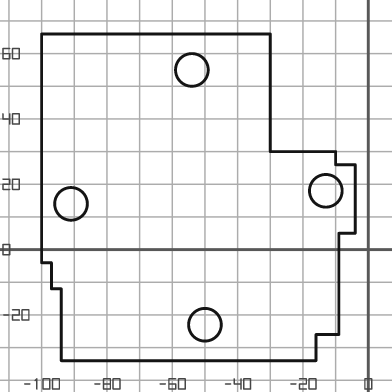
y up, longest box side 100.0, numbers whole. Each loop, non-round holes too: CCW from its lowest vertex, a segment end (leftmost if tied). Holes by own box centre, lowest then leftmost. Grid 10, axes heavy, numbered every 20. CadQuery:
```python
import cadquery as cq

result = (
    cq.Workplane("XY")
    .moveTo(-94.0, -34.0)
    .lineTo(-16.0, -34.0)
    .lineTo(-16.0, -26.0)
    .lineTo(-9.0, -26.0)
    .lineTo(-9.0, 5.0)
    .lineTo(-4.0, 5.0)
    .lineTo(-4.0, 26.0)
    .lineTo(-10.0, 26.0)
    .lineTo(-10.0, 30.0)
    .lineTo(-30.0, 30.0)
    .lineTo(-30.0, 66.0)
    .lineTo(-100.0, 66.0)
    .lineTo(-100.0, -4.0)
    .lineTo(-97.0, -4.0)
    .lineTo(-97.0, -12.0)
    .lineTo(-94.0, -12.0)
    .close()
    .moveTo(-50.0, -23.0)
    .circle(5.0)
    .moveTo(-91.0, 14.0)
    .circle(5.0)
    .moveTo(-13.0, 18.0)
    .circle(5.0)
    .moveTo(-54.0, 55.0)
    .circle(5.0)
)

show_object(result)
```